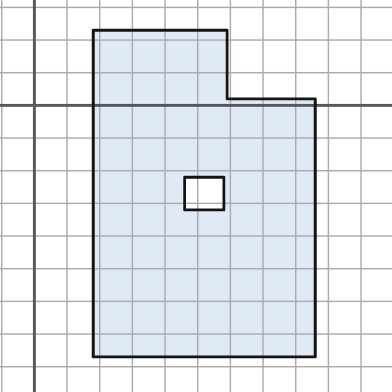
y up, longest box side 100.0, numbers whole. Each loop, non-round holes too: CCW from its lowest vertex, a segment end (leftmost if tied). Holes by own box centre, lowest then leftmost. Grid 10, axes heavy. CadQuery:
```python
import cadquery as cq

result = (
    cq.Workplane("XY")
    .moveTo(18.0, -77.0)
    .lineTo(86.0, -77.0)
    .lineTo(86.0, 2.0)
    .lineTo(59.0, 2.0)
    .lineTo(59.0, 23.0)
    .lineTo(18.0, 23.0)
    .close()
    .moveTo(46.0, -32.0)
    .lineTo(58.0, -32.0)
    .lineTo(58.0, -22.0)
    .lineTo(46.0, -22.0)
    .close()
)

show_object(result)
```